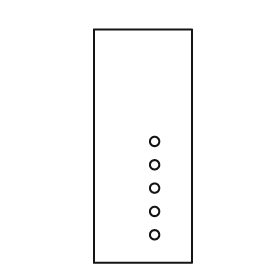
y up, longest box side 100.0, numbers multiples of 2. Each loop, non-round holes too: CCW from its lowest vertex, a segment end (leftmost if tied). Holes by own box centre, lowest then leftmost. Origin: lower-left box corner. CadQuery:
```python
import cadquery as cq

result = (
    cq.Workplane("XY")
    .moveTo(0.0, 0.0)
    .lineTo(42.0, 0.0)
    .lineTo(42.0, 100.0)
    .lineTo(0.0, 100.0)
    .close()
    .moveTo(26.0, 12.0)
    .circle(2.0)
    .moveTo(26.0, 22.0)
    .circle(2.0)
    .moveTo(26.0, 32.0)
    .circle(2.0)
    .moveTo(26.0, 42.0)
    .circle(2.0)
    .moveTo(26.0, 52.0)
    .circle(2.0)
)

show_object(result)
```